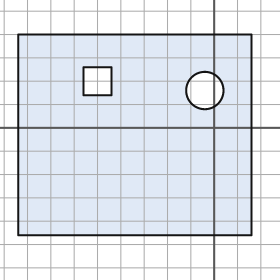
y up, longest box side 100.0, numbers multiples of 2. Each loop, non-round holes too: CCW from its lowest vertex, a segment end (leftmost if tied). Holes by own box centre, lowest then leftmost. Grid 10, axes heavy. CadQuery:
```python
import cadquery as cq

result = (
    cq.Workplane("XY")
    .moveTo(-84.0, -46.0)
    .lineTo(16.0, -46.0)
    .lineTo(16.0, 40.0)
    .lineTo(-84.0, 40.0)
    .close()
    .moveTo(-4.0, 16.0)
    .circle(8.0)
    .moveTo(-56.0, 14.0)
    .lineTo(-44.0, 14.0)
    .lineTo(-44.0, 26.0)
    .lineTo(-56.0, 26.0)
    .close()
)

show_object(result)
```